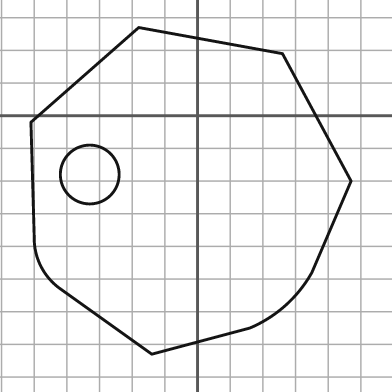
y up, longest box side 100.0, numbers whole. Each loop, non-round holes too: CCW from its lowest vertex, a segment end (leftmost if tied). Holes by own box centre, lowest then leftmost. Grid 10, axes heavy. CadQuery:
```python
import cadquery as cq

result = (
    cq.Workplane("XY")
    .moveTo(-14.0, -73.0)
    .lineTo(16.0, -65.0)
    .threePointArc((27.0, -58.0), (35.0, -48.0))
    .lineTo(47.0, -20.0)
    .lineTo(26.0, 19.0)
    .lineTo(-18.0, 27.0)
    .lineTo(-51.0, -2.0)
    .lineTo(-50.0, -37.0)
    .threePointArc((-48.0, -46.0), (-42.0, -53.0))
    .close()
    .moveTo(-33.0, -18.0)
    .circle(9.0)
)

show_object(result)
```